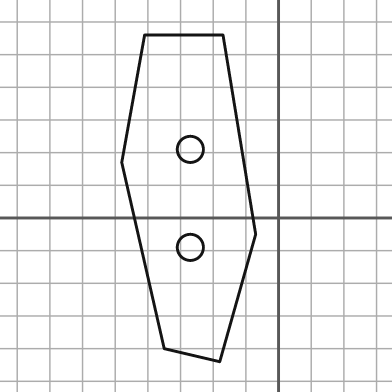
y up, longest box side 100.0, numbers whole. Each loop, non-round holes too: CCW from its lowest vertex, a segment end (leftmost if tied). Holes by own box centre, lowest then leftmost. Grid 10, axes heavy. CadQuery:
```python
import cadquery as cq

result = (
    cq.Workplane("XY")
    .moveTo(-18.0, -44.0)
    .lineTo(-7.0, -5.0)
    .lineTo(-17.0, 56.0)
    .lineTo(-41.0, 56.0)
    .lineTo(-48.0, 17.0)
    .lineTo(-35.0, -40.0)
    .close()
    .moveTo(-27.0, -9.0)
    .circle(4.0)
    .moveTo(-27.0, 21.0)
    .circle(4.0)
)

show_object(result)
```